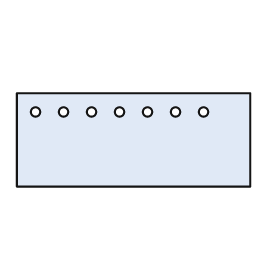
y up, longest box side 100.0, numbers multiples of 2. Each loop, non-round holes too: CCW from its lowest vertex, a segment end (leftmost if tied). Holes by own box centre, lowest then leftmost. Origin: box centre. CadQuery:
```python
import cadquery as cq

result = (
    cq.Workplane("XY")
    .moveTo(-50.0, -20.0)
    .lineTo(50.0, -20.0)
    .lineTo(50.0, 20.0)
    .lineTo(-50.0, 20.0)
    .close()
    .moveTo(-42.0, 12.0)
    .circle(2.0)
    .moveTo(-30.0, 12.0)
    .circle(2.0)
    .moveTo(-18.0, 12.0)
    .circle(2.0)
    .moveTo(-6.0, 12.0)
    .circle(2.0)
    .moveTo(6.0, 12.0)
    .circle(2.0)
    .moveTo(18.0, 12.0)
    .circle(2.0)
    .moveTo(30.0, 12.0)
    .circle(2.0)
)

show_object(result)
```